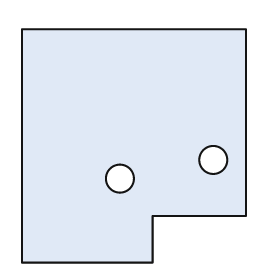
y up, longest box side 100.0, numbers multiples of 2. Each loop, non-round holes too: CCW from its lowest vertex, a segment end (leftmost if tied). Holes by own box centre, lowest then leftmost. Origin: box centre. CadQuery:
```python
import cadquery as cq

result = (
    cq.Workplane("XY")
    .moveTo(-48.0, -50.0)
    .lineTo(8.0, -50.0)
    .lineTo(8.0, -30.0)
    .lineTo(48.0, -30.0)
    .lineTo(48.0, 50.0)
    .lineTo(-48.0, 50.0)
    .close()
    .moveTo(-6.0, -14.0)
    .circle(6.0)
    .moveTo(34.0, -6.0)
    .circle(6.0)
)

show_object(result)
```